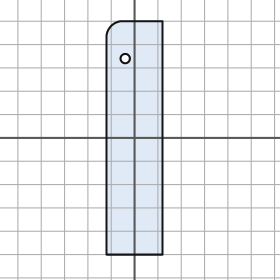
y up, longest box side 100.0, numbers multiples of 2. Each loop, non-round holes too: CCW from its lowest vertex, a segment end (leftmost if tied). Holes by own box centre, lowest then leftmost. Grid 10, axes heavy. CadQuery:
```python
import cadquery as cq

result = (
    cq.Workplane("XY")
    .moveTo(-12.0, -50.0)
    .lineTo(12.0, -50.0)
    .lineTo(12.0, 50.0)
    .lineTo(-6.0, 50.0)
    .threePointArc((-10.0, 48.0), (-12.0, 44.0))
    .close()
    .moveTo(-4.0, 34.0)
    .circle(2.0)
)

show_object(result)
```